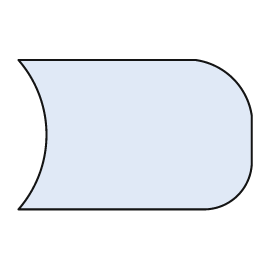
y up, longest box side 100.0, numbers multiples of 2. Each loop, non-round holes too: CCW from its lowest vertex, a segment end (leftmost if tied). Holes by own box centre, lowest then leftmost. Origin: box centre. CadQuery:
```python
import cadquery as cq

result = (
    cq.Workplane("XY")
    .moveTo(-50.0, -32.0)
    .lineTo(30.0, -32.0)
    .threePointArc((44.0, -26.0), (50.0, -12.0))
    .lineTo(50.0, 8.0)
    .threePointArc((42.0, 24.0), (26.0, 32.0))
    .lineTo(-50.0, 32.0)
    .threePointArc((-38.0, 0.0), (-50.0, -32.0))
    .close()
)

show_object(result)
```